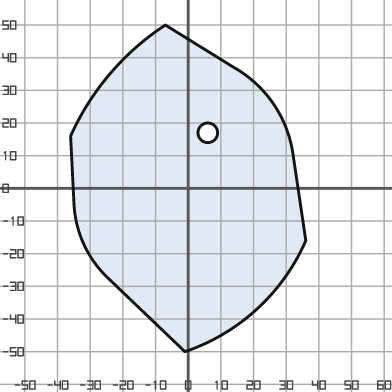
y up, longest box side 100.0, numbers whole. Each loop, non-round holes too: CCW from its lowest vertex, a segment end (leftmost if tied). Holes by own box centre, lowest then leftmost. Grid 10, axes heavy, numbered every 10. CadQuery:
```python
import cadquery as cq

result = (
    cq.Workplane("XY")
    .moveTo(-1.0, -50.0)
    .threePointArc((21.0, -37.0), (36.0, -16.0))
    .lineTo(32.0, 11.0)
    .threePointArc((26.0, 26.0), (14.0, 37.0))
    .lineTo(-7.0, 50.0)
    .threePointArc((-24.0, 35.0), (-36.0, 16.0))
    .lineTo(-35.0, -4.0)
    .threePointArc((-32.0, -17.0), (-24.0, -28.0))
    .close()
    .moveTo(6.0, 17.0)
    .circle(3.0)
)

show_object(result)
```